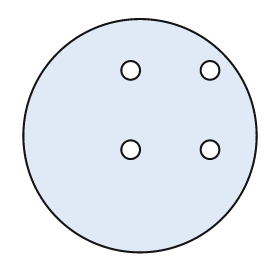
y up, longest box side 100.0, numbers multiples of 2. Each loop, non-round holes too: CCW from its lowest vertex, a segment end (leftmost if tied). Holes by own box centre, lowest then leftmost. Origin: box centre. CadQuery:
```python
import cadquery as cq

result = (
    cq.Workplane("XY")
    .moveTo(0.0, 0.0)
    .circle(50.0)
    .moveTo(-4.0, -6.0)
    .circle(4.0)
    .moveTo(30.0, -6.0)
    .circle(4.0)
    .moveTo(-4.0, 28.0)
    .circle(4.0)
    .moveTo(30.0, 28.0)
    .circle(4.0)
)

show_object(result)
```